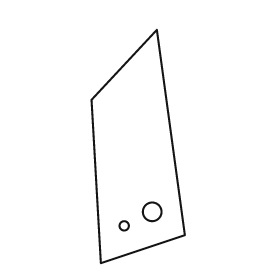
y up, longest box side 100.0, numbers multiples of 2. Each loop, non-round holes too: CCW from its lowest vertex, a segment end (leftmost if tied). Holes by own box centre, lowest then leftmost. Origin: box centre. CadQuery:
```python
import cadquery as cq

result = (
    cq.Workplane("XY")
    .moveTo(-16.0, -50.0)
    .lineTo(20.0, -38.0)
    .lineTo(8.0, 50.0)
    .lineTo(-20.0, 20.0)
    .close()
    .moveTo(-6.0, -34.0)
    .circle(2.0)
    .moveTo(6.0, -28.0)
    .circle(4.0)
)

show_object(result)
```